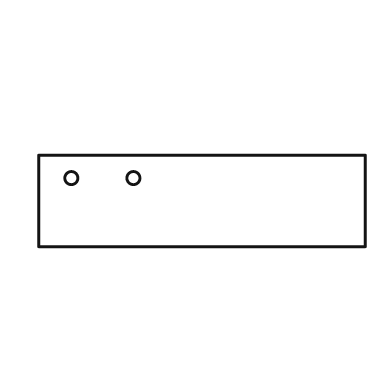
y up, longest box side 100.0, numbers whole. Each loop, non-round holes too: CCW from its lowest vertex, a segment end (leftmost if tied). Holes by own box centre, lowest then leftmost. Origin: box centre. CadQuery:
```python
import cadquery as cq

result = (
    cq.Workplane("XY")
    .moveTo(-50.0, -14.0)
    .lineTo(50.0, -14.0)
    .lineTo(50.0, 14.0)
    .lineTo(-50.0, 14.0)
    .close()
    .moveTo(-40.0, 7.0)
    .circle(2.0)
    .moveTo(-21.0, 7.0)
    .circle(2.0)
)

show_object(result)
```